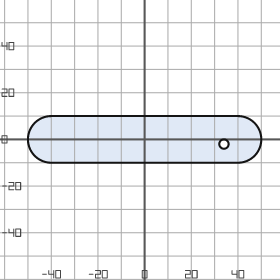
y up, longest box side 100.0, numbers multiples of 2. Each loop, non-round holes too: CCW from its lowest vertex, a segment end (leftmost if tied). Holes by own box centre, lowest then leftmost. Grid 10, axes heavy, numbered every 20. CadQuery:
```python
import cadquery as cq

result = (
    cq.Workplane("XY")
    .moveTo(-40.0, -10.0)
    .lineTo(40.0, -10.0)
    .threePointArc((50.0, 0.0), (40.0, 10.0))
    .lineTo(-40.0, 10.0)
    .threePointArc((-50.0, 0.0), (-40.0, -10.0))
    .close()
    .moveTo(34.0, -2.0)
    .circle(2.0)
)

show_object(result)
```